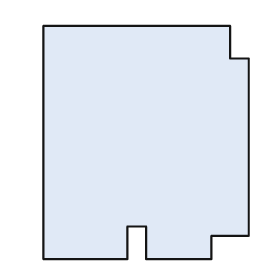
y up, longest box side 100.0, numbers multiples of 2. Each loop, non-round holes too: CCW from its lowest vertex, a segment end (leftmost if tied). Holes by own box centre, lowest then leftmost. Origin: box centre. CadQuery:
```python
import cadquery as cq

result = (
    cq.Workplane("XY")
    .moveTo(-44.0, -50.0)
    .lineTo(-8.0, -50.0)
    .lineTo(-8.0, -36.0)
    .lineTo(0.0, -36.0)
    .lineTo(0.0, -50.0)
    .lineTo(28.0, -50.0)
    .lineTo(28.0, -40.0)
    .lineTo(44.0, -40.0)
    .lineTo(44.0, 36.0)
    .lineTo(36.0, 36.0)
    .lineTo(36.0, 50.0)
    .lineTo(-44.0, 50.0)
    .close()
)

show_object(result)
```